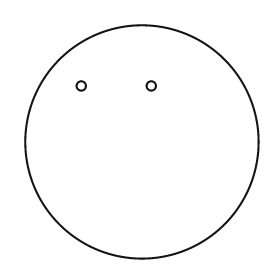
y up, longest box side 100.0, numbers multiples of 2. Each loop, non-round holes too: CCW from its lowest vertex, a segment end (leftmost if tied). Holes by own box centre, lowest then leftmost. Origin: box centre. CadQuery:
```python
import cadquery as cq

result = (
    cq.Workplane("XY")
    .moveTo(0.0, 0.0)
    .circle(50.0)
    .moveTo(-26.0, 24.0)
    .circle(2.0)
    .moveTo(4.0, 24.0)
    .circle(2.0)
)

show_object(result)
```